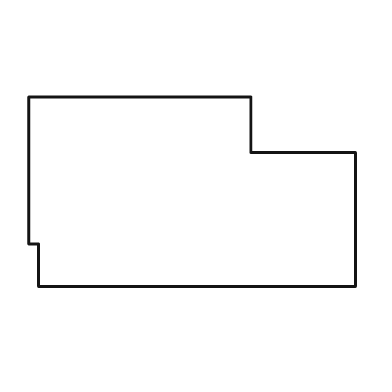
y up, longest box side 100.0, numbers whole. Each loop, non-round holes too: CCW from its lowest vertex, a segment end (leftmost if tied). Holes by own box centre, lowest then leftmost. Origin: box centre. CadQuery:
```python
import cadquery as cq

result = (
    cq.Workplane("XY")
    .moveTo(-47.0, -29.0)
    .lineTo(50.0, -29.0)
    .lineTo(50.0, 12.0)
    .lineTo(18.0, 12.0)
    .lineTo(18.0, 29.0)
    .lineTo(-50.0, 29.0)
    .lineTo(-50.0, -16.0)
    .lineTo(-47.0, -16.0)
    .close()
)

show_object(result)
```